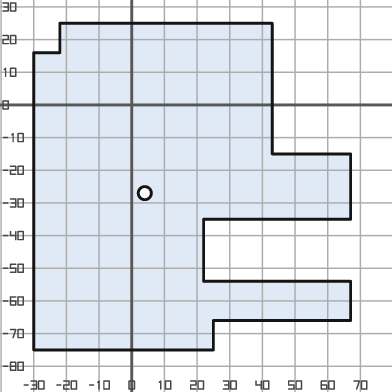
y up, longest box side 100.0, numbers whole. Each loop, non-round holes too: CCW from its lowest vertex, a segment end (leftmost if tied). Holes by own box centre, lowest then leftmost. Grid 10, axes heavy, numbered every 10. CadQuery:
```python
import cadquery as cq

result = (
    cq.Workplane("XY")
    .moveTo(-30.0, -75.0)
    .lineTo(25.0, -75.0)
    .lineTo(25.0, -66.0)
    .lineTo(67.0, -66.0)
    .lineTo(67.0, -54.0)
    .lineTo(22.0, -54.0)
    .lineTo(22.0, -35.0)
    .lineTo(67.0, -35.0)
    .lineTo(67.0, -15.0)
    .lineTo(43.0, -15.0)
    .lineTo(43.0, 25.0)
    .lineTo(-22.0, 25.0)
    .lineTo(-22.0, 16.0)
    .lineTo(-30.0, 16.0)
    .close()
    .moveTo(4.0, -27.0)
    .circle(2.0)
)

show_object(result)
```